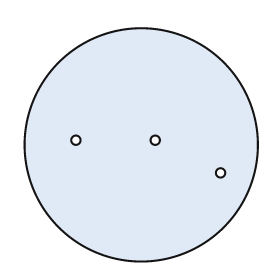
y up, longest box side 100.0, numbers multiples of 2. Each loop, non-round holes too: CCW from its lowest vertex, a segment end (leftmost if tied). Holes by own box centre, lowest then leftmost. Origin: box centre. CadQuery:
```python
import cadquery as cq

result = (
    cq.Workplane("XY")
    .moveTo(0.0, 0.0)
    .circle(50.0)
    .moveTo(34.0, -12.0)
    .circle(2.0)
    .moveTo(-28.0, 2.0)
    .circle(2.0)
    .moveTo(6.0, 2.0)
    .circle(2.0)
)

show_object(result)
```